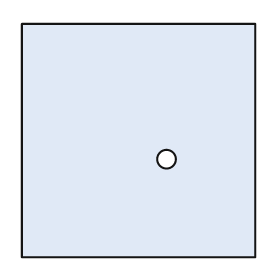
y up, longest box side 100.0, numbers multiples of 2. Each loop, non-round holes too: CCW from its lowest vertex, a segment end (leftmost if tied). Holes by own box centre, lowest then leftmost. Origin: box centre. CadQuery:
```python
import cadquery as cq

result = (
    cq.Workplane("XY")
    .moveTo(-50.0, -50.0)
    .lineTo(50.0, -50.0)
    .lineTo(50.0, 50.0)
    .lineTo(-50.0, 50.0)
    .close()
    .moveTo(12.0, -8.0)
    .circle(4.0)
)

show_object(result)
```